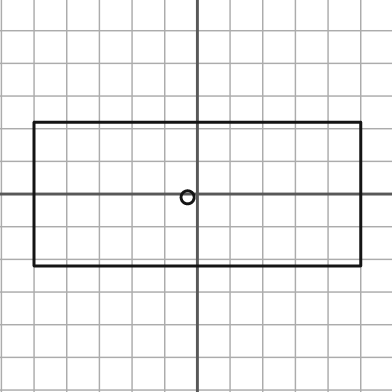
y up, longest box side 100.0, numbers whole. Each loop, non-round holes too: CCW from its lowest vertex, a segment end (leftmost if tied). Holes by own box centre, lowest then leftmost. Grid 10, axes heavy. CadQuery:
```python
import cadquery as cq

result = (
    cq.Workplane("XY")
    .moveTo(-50.0, -22.0)
    .lineTo(50.0, -22.0)
    .lineTo(50.0, 22.0)
    .lineTo(-50.0, 22.0)
    .close()
    .moveTo(-3.0, -1.0)
    .circle(2.0)
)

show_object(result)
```